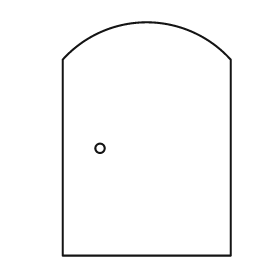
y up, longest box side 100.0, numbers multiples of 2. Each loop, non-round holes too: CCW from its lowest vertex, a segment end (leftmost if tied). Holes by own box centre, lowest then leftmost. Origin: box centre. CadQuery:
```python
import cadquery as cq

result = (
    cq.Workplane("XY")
    .moveTo(-36.0, -50.0)
    .lineTo(36.0, -50.0)
    .lineTo(36.0, 34.0)
    .threePointArc((0.0, 50.0), (-36.0, 34.0))
    .close()
    .moveTo(-20.0, -4.0)
    .circle(2.0)
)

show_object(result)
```